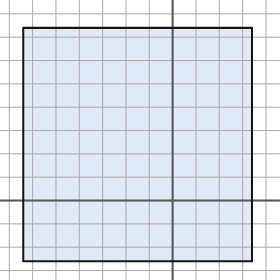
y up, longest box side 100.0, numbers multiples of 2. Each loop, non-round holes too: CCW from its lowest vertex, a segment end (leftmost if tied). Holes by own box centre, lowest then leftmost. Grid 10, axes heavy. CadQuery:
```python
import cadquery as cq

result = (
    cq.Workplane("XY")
    .moveTo(-64.0, -26.0)
    .lineTo(34.0, -26.0)
    .lineTo(34.0, 74.0)
    .lineTo(-64.0, 74.0)
    .close()
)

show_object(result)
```